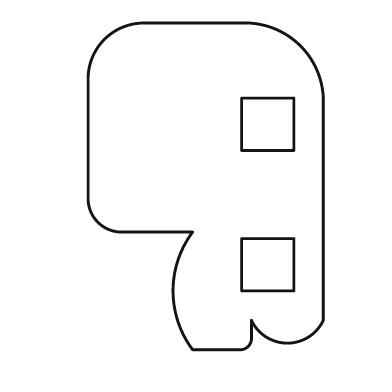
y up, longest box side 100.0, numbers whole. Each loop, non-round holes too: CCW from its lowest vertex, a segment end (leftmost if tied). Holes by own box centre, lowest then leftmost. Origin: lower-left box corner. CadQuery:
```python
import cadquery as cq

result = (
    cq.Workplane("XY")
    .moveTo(32.0, 0.0)
    .lineTo(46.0, 0.0)
    .threePointArc((49.0, 1.0), (50.0, 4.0))
    .lineTo(50.0, 9.0)
    .threePointArc((61.0, 2.0), (72.0, 9.0))
    .lineTo(72.0, 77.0)
    .threePointArc((65.0, 93.0), (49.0, 100.0))
    .lineTo(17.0, 100.0)
    .threePointArc((5.0, 95.0), (0.0, 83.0))
    .lineTo(0.0, 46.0)
    .threePointArc((3.0, 39.0), (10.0, 36.0))
    .lineTo(32.0, 36.0)
    .threePointArc((26.0, 18.0), (32.0, 0.0))
    .close()
    .moveTo(47.0, 18.0)
    .lineTo(63.0, 18.0)
    .lineTo(63.0, 34.0)
    .lineTo(47.0, 34.0)
    .close()
    .moveTo(47.0, 61.0)
    .lineTo(63.0, 61.0)
    .lineTo(63.0, 77.0)
    .lineTo(47.0, 77.0)
    .close()
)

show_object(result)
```